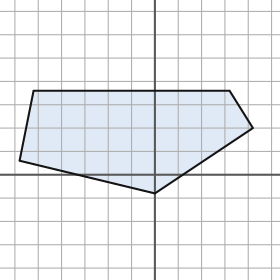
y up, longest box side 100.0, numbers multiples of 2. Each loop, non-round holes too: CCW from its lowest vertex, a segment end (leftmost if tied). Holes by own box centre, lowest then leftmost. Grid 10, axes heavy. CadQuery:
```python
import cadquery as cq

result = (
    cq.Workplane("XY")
    .moveTo(0.0, -8.0)
    .lineTo(42.0, 20.0)
    .lineTo(32.0, 36.0)
    .lineTo(-52.0, 36.0)
    .lineTo(-58.0, 6.0)
    .close()
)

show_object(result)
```